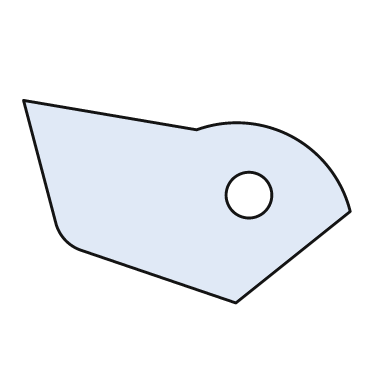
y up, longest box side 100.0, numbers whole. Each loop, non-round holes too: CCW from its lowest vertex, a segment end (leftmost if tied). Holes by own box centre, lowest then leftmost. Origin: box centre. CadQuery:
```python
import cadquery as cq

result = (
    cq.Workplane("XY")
    .moveTo(15.0, -31.0)
    .lineTo(50.0, -3.0)
    .threePointArc((32.0, 20.0), (3.0, 22.0))
    .lineTo(-50.0, 31.0)
    .lineTo(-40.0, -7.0)
    .threePointArc((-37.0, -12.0), (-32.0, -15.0))
    .close()
    .moveTo(19.0, 2.0)
    .circle(7.0)
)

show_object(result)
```